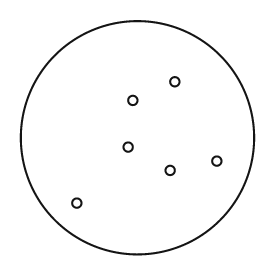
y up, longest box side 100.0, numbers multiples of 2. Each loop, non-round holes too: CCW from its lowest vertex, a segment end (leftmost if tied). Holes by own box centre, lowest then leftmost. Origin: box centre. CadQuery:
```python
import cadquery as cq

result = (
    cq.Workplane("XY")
    .moveTo(0.0, 0.0)
    .circle(50.0)
    .moveTo(-26.0, -28.0)
    .circle(2.0)
    .moveTo(14.0, -14.0)
    .circle(2.0)
    .moveTo(34.0, -10.0)
    .circle(2.0)
    .moveTo(-4.0, -4.0)
    .circle(2.0)
    .moveTo(-2.0, 16.0)
    .circle(2.0)
    .moveTo(16.0, 24.0)
    .circle(2.0)
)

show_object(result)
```